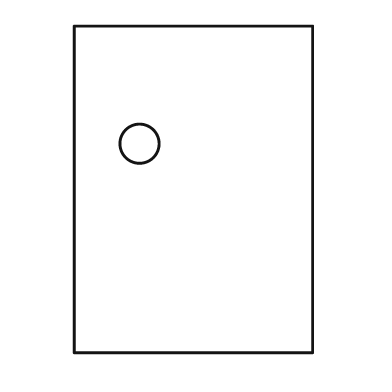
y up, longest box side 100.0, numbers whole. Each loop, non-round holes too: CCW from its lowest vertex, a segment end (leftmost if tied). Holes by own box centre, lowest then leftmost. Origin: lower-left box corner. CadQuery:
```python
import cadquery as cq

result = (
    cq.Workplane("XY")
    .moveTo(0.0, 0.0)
    .lineTo(73.0, 0.0)
    .lineTo(73.0, 100.0)
    .lineTo(0.0, 100.0)
    .close()
    .moveTo(20.0, 64.0)
    .circle(6.0)
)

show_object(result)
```